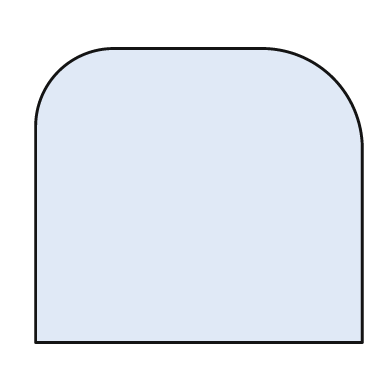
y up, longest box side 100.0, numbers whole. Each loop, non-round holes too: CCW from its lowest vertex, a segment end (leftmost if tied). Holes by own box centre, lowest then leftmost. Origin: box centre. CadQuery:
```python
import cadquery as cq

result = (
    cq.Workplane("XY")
    .moveTo(-50.0, -45.0)
    .lineTo(50.0, -45.0)
    .lineTo(50.0, 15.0)
    .threePointArc((41.0, 36.0), (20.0, 45.0))
    .lineTo(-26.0, 45.0)
    .threePointArc((-43.0, 38.0), (-50.0, 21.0))
    .close()
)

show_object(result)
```